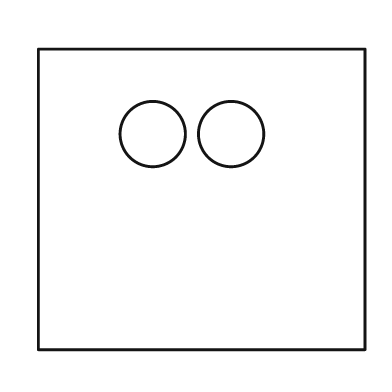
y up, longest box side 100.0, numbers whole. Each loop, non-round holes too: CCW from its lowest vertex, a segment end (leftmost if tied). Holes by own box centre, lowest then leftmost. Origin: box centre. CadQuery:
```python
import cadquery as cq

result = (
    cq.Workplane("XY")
    .moveTo(-50.0, -46.0)
    .lineTo(50.0, -46.0)
    .lineTo(50.0, 46.0)
    .lineTo(-50.0, 46.0)
    .close()
    .moveTo(-15.0, 20.0)
    .circle(10.0)
    .moveTo(9.0, 20.0)
    .circle(10.0)
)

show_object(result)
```